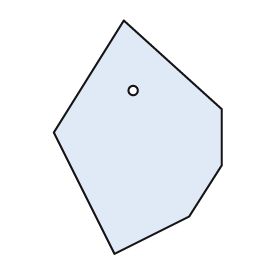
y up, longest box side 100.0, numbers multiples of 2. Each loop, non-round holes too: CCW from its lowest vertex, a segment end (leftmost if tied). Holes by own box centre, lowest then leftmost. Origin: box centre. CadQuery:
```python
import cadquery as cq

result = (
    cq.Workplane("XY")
    .moveTo(-10.0, -50.0)
    .lineTo(22.0, -34.0)
    .lineTo(36.0, -12.0)
    .lineTo(36.0, 12.0)
    .lineTo(-6.0, 50.0)
    .lineTo(-36.0, 2.0)
    .close()
    .moveTo(-2.0, 20.0)
    .circle(2.0)
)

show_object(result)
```